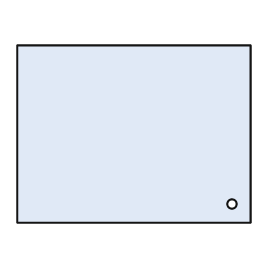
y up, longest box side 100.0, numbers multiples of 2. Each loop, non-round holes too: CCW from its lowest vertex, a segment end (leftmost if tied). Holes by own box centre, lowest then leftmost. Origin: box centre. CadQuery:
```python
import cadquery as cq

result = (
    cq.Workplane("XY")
    .moveTo(-50.0, -38.0)
    .lineTo(50.0, -38.0)
    .lineTo(50.0, 38.0)
    .lineTo(-50.0, 38.0)
    .close()
    .moveTo(42.0, -30.0)
    .circle(2.0)
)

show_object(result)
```